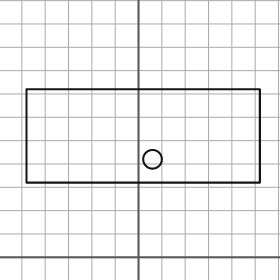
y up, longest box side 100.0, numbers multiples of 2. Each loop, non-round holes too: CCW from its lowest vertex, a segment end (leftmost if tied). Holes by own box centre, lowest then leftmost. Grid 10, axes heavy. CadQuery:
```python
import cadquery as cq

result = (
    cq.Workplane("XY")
    .moveTo(-48.0, 32.0)
    .lineTo(52.0, 32.0)
    .lineTo(52.0, 72.0)
    .lineTo(-48.0, 72.0)
    .close()
    .moveTo(6.0, 42.0)
    .circle(4.0)
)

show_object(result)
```